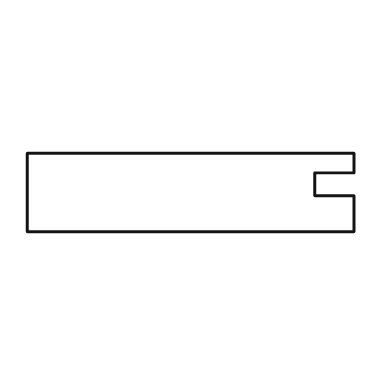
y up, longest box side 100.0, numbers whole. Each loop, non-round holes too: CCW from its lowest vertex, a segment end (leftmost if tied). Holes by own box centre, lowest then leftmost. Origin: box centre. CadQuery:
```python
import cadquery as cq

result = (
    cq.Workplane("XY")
    .moveTo(-50.0, -12.0)
    .lineTo(50.0, -12.0)
    .lineTo(50.0, -1.0)
    .lineTo(38.0, -1.0)
    .lineTo(38.0, 6.0)
    .lineTo(50.0, 6.0)
    .lineTo(50.0, 12.0)
    .lineTo(-50.0, 12.0)
    .close()
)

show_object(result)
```